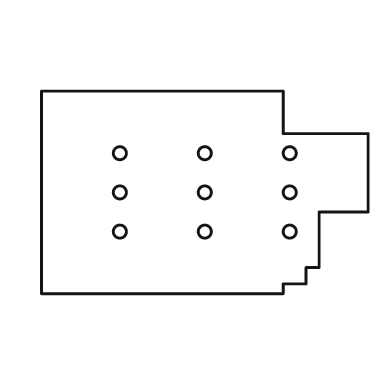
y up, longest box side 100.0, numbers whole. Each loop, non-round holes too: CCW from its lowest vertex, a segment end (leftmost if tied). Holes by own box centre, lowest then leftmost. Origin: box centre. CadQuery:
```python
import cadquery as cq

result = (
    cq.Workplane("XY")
    .moveTo(-50.0, -31.0)
    .lineTo(24.0, -31.0)
    .lineTo(24.0, -28.0)
    .lineTo(31.0, -28.0)
    .lineTo(31.0, -23.0)
    .lineTo(35.0, -23.0)
    .lineTo(35.0, -6.0)
    .lineTo(50.0, -6.0)
    .lineTo(50.0, 18.0)
    .lineTo(24.0, 18.0)
    .lineTo(24.0, 31.0)
    .lineTo(-50.0, 31.0)
    .close()
    .moveTo(-26.0, -12.0)
    .circle(2.0)
    .moveTo(0.0, -12.0)
    .circle(2.0)
    .moveTo(26.0, -12.0)
    .circle(2.0)
    .moveTo(-26.0, 0.0)
    .circle(2.0)
    .moveTo(0.0, 0.0)
    .circle(2.0)
    .moveTo(26.0, 0.0)
    .circle(2.0)
    .moveTo(-26.0, 12.0)
    .circle(2.0)
    .moveTo(0.0, 12.0)
    .circle(2.0)
    .moveTo(26.0, 12.0)
    .circle(2.0)
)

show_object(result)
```